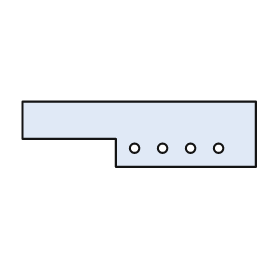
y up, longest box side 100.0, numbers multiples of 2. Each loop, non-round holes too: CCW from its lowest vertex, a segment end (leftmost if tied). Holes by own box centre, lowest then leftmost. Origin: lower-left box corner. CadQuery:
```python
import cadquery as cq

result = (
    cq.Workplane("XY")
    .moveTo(40.0, 0.0)
    .lineTo(100.0, 0.0)
    .lineTo(100.0, 28.0)
    .lineTo(0.0, 28.0)
    .lineTo(0.0, 12.0)
    .lineTo(40.0, 12.0)
    .close()
    .moveTo(48.0, 8.0)
    .circle(2.0)
    .moveTo(60.0, 8.0)
    .circle(2.0)
    .moveTo(72.0, 8.0)
    .circle(2.0)
    .moveTo(84.0, 8.0)
    .circle(2.0)
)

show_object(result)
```